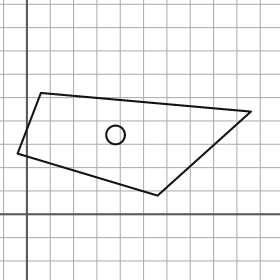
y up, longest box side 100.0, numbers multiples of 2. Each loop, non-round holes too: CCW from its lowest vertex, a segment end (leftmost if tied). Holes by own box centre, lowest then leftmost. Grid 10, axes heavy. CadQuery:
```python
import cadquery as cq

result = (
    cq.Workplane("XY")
    .moveTo(56.0, 8.0)
    .lineTo(96.0, 44.0)
    .lineTo(6.0, 52.0)
    .lineTo(-4.0, 26.0)
    .close()
    .moveTo(38.0, 34.0)
    .circle(4.0)
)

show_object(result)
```